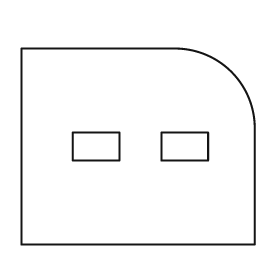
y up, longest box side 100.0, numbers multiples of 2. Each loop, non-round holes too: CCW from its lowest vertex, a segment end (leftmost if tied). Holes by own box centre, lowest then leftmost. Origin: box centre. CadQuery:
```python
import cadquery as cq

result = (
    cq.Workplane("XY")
    .moveTo(-50.0, -42.0)
    .lineTo(50.0, -42.0)
    .lineTo(50.0, 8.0)
    .threePointArc((40.0, 32.0), (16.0, 42.0))
    .lineTo(-50.0, 42.0)
    .close()
    .moveTo(-28.0, -6.0)
    .lineTo(-8.0, -6.0)
    .lineTo(-8.0, 6.0)
    .lineTo(-28.0, 6.0)
    .close()
    .moveTo(10.0, -6.0)
    .lineTo(30.0, -6.0)
    .lineTo(30.0, 6.0)
    .lineTo(10.0, 6.0)
    .close()
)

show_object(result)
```